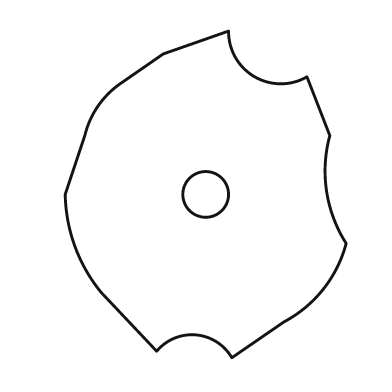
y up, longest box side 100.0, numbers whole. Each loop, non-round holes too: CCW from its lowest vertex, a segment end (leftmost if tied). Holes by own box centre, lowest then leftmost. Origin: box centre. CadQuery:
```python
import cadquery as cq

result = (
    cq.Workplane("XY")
    .moveTo(8.0, -50.0)
    .lineTo(24.0, -39.0)
    .threePointArc((36.0, -29.0), (43.0, -15.0))
    .threePointArc((37.0, 1.0), (38.0, 18.0))
    .lineTo(31.0, 36.0)
    .threePointArc((15.0, 36.0), (7.0, 50.0))
    .lineTo(-13.0, 43.0)
    .lineTo(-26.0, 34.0)
    .threePointArc((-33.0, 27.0), (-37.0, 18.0))
    .lineTo(-43.0, 0.0)
    .threePointArc((-40.0, -16.0), (-32.0, -30.0))
    .lineTo(-15.0, -48.0)
    .threePointArc((-3.0, -43.0), (8.0, -50.0))
    .close()
    .moveTo(0.0, 0.0)
    .circle(7.0)
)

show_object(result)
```